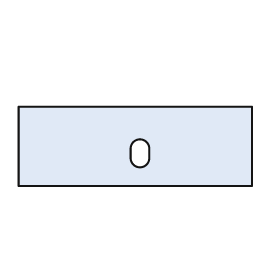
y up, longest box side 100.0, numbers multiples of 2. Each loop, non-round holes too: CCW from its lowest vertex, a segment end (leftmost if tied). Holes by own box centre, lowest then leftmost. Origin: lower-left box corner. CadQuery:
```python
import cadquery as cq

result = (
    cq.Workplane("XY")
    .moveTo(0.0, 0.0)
    .lineTo(100.0, 0.0)
    .lineTo(100.0, 34.0)
    .lineTo(0.0, 34.0)
    .close()
    .moveTo(48.0, 12.0)
    .threePointArc((52.0, 8.0), (56.0, 12.0))
    .lineTo(56.0, 16.0)
    .threePointArc((52.0, 20.0), (48.0, 16.0))
    .close()
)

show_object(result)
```